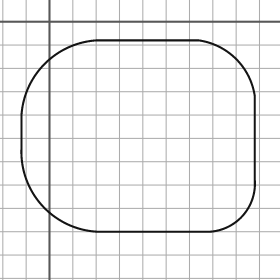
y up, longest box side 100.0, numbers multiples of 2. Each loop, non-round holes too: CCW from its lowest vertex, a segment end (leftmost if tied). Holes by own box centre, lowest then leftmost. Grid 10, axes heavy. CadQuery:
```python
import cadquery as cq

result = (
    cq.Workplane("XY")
    .moveTo(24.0, -90.0)
    .lineTo(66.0, -90.0)
    .threePointArc((82.0, -84.0), (88.0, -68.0))
    .lineTo(88.0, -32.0)
    .threePointArc((80.0, -16.0), (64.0, -8.0))
    .lineTo(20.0, -8.0)
    .threePointArc((-2.0, -18.0), (-12.0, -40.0))
    .lineTo(-12.0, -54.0)
    .threePointArc((-2.0, -80.0), (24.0, -90.0))
    .close()
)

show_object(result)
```